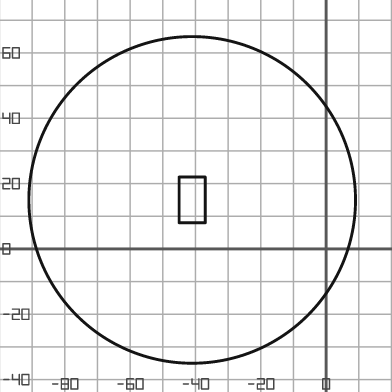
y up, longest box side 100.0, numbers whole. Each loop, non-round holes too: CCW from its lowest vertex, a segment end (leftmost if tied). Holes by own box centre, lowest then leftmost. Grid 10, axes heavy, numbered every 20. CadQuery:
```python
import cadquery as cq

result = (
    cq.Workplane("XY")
    .moveTo(-41.0, 15.0)
    .circle(50.0)
    .moveTo(-45.0, 8.0)
    .lineTo(-37.0, 8.0)
    .lineTo(-37.0, 22.0)
    .lineTo(-45.0, 22.0)
    .close()
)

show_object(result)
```